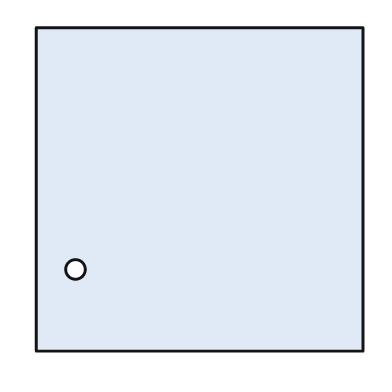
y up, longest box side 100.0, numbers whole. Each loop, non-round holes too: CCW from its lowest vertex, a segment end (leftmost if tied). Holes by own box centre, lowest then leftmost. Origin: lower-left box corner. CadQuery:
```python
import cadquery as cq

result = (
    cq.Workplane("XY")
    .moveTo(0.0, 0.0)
    .lineTo(100.0, 0.0)
    .lineTo(100.0, 99.0)
    .lineTo(0.0, 99.0)
    .close()
    .moveTo(12.0, 25.0)
    .circle(3.0)
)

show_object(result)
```